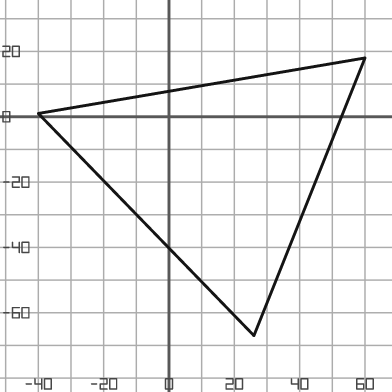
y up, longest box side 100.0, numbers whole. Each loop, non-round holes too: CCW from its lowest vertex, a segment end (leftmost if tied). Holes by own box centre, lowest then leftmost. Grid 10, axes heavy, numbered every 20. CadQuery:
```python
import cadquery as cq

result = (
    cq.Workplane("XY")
    .moveTo(26.0, -67.0)
    .lineTo(60.0, 18.0)
    .lineTo(-40.0, 1.0)
    .close()
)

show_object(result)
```